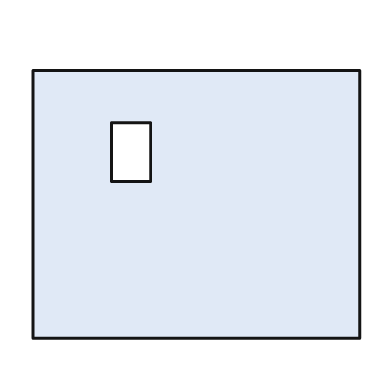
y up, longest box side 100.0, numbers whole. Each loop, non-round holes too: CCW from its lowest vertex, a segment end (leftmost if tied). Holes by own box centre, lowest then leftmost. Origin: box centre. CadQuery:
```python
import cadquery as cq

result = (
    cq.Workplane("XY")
    .moveTo(-50.0, -41.0)
    .lineTo(50.0, -41.0)
    .lineTo(50.0, 41.0)
    .lineTo(-50.0, 41.0)
    .close()
    .moveTo(-26.0, 7.0)
    .lineTo(-14.0, 7.0)
    .lineTo(-14.0, 25.0)
    .lineTo(-26.0, 25.0)
    .close()
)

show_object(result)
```